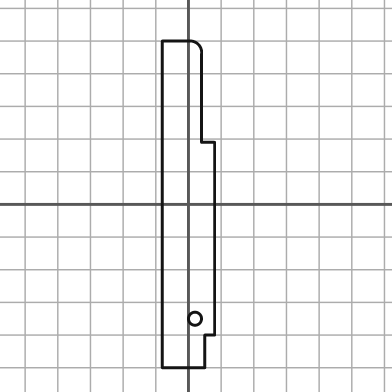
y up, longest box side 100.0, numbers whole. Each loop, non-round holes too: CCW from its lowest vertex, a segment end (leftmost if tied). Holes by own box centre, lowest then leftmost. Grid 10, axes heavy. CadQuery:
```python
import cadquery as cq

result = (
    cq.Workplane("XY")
    .moveTo(-8.0, -50.0)
    .lineTo(5.0, -50.0)
    .lineTo(5.0, -40.0)
    .lineTo(8.0, -40.0)
    .lineTo(8.0, 19.0)
    .lineTo(4.0, 19.0)
    .lineTo(4.0, 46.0)
    .threePointArc((3.0, 49.0), (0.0, 50.0))
    .lineTo(-8.0, 50.0)
    .close()
    .moveTo(2.0, -35.0)
    .circle(2.0)
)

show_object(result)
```